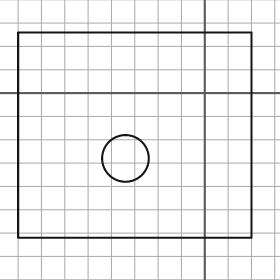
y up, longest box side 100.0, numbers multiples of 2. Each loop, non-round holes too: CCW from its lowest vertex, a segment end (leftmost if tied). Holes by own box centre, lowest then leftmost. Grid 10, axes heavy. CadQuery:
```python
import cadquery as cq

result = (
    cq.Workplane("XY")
    .moveTo(-80.0, -62.0)
    .lineTo(20.0, -62.0)
    .lineTo(20.0, 26.0)
    .lineTo(-80.0, 26.0)
    .close()
    .moveTo(-34.0, -28.0)
    .circle(10.0)
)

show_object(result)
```